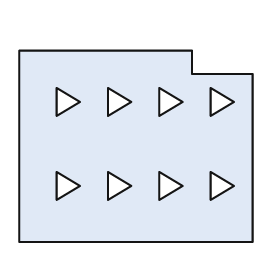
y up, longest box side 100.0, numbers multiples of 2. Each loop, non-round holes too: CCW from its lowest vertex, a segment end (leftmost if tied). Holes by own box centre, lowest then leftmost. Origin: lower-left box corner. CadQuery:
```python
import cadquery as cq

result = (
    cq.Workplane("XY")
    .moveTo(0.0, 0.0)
    .lineTo(100.0, 0.0)
    .lineTo(100.0, 72.0)
    .lineTo(74.0, 72.0)
    .lineTo(74.0, 82.0)
    .lineTo(0.0, 82.0)
    .close()
    .moveTo(16.0, 18.0)
    .lineTo(26.0, 24.0)
    .lineTo(16.0, 30.0)
    .close()
    .moveTo(38.0, 18.0)
    .lineTo(48.0, 24.0)
    .lineTo(38.0, 30.0)
    .close()
    .moveTo(60.0, 18.0)
    .lineTo(70.0, 24.0)
    .lineTo(60.0, 30.0)
    .close()
    .moveTo(82.0, 18.0)
    .lineTo(92.0, 24.0)
    .lineTo(82.0, 30.0)
    .close()
    .moveTo(16.0, 54.0)
    .lineTo(26.0, 60.0)
    .lineTo(16.0, 66.0)
    .close()
    .moveTo(38.0, 54.0)
    .lineTo(48.0, 60.0)
    .lineTo(38.0, 66.0)
    .close()
    .moveTo(60.0, 54.0)
    .lineTo(70.0, 60.0)
    .lineTo(60.0, 66.0)
    .close()
    .moveTo(82.0, 54.0)
    .lineTo(92.0, 60.0)
    .lineTo(82.0, 66.0)
    .close()
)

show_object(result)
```